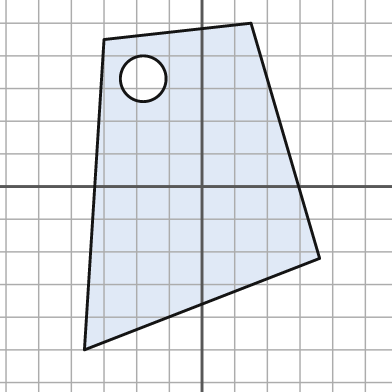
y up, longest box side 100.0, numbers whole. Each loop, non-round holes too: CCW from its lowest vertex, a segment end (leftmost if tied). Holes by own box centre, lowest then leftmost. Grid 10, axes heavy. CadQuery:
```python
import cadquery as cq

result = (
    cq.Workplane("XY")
    .moveTo(-36.0, -50.0)
    .lineTo(36.0, -22.0)
    .lineTo(15.0, 50.0)
    .lineTo(-30.0, 45.0)
    .close()
    .moveTo(-18.0, 33.0)
    .circle(7.0)
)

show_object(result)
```